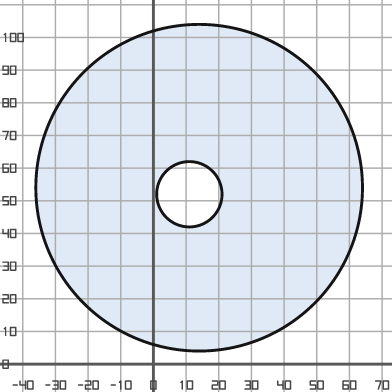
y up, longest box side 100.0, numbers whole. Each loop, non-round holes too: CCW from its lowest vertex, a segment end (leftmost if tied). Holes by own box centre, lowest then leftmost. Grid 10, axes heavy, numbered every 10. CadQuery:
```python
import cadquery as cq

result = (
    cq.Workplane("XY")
    .moveTo(14.0, 54.0)
    .circle(50.0)
    .moveTo(11.0, 52.0)
    .circle(10.0)
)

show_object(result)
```